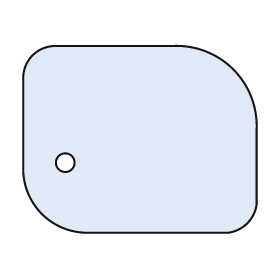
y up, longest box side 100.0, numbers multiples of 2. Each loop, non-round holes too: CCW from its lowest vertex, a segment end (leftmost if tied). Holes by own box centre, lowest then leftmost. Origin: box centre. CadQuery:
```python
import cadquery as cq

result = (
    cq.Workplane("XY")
    .moveTo(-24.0, -40.0)
    .lineTo(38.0, -40.0)
    .threePointArc((46.0, -36.0), (50.0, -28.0))
    .lineTo(50.0, 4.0)
    .threePointArc((40.0, 30.0), (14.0, 40.0))
    .lineTo(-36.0, 40.0)
    .threePointArc((-46.0, 36.0), (-50.0, 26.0))
    .lineTo(-50.0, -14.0)
    .threePointArc((-42.0, -32.0), (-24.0, -40.0))
    .close()
    .moveTo(-32.0, -10.0)
    .circle(4.0)
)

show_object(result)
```